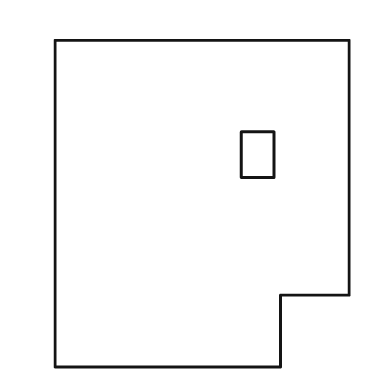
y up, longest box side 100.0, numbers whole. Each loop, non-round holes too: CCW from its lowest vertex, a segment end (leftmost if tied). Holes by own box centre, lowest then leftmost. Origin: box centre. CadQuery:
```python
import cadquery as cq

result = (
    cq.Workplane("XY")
    .moveTo(-45.0, -50.0)
    .lineTo(24.0, -50.0)
    .lineTo(24.0, -28.0)
    .lineTo(45.0, -28.0)
    .lineTo(45.0, 50.0)
    .lineTo(-45.0, 50.0)
    .close()
    .moveTo(12.0, 8.0)
    .lineTo(22.0, 8.0)
    .lineTo(22.0, 22.0)
    .lineTo(12.0, 22.0)
    .close()
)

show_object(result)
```